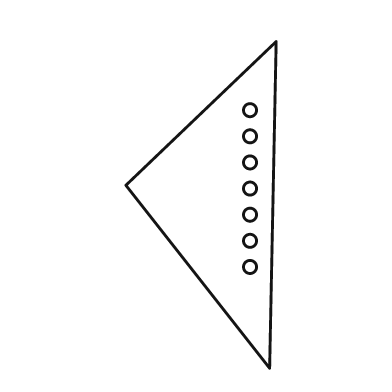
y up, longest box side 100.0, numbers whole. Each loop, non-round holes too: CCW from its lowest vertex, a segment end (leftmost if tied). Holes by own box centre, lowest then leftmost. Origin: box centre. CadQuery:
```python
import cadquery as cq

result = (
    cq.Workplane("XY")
    .moveTo(21.0, -50.0)
    .lineTo(23.0, 50.0)
    .lineTo(-23.0, 6.0)
    .close()
    .moveTo(15.0, -19.0)
    .circle(2.0)
    .moveTo(15.0, -11.0)
    .circle(2.0)
    .moveTo(15.0, -3.0)
    .circle(2.0)
    .moveTo(15.0, 5.0)
    .circle(2.0)
    .moveTo(15.0, 13.0)
    .circle(2.0)
    .moveTo(15.0, 21.0)
    .circle(2.0)
    .moveTo(15.0, 29.0)
    .circle(2.0)
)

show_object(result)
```